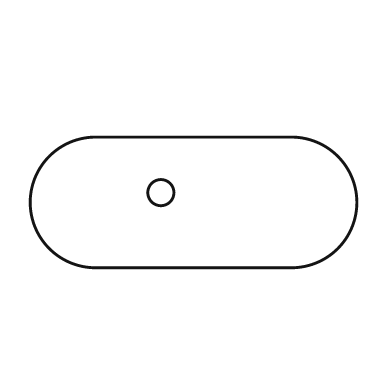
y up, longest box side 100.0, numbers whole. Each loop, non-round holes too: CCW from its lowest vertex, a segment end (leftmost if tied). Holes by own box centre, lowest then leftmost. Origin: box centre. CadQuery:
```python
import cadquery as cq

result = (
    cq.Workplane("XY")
    .moveTo(-30.0, -20.0)
    .lineTo(30.0, -20.0)
    .threePointArc((50.0, 0.0), (30.0, 20.0))
    .lineTo(-30.0, 20.0)
    .threePointArc((-50.0, 0.0), (-30.0, -20.0))
    .close()
    .moveTo(-10.0, 3.0)
    .circle(4.0)
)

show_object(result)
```